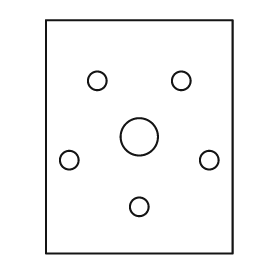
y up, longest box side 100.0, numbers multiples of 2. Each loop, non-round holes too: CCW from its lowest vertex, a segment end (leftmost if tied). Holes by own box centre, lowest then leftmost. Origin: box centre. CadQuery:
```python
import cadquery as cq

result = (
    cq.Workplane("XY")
    .moveTo(-40.0, -50.0)
    .lineTo(40.0, -50.0)
    .lineTo(40.0, 50.0)
    .lineTo(-40.0, 50.0)
    .close()
    .moveTo(0.0, -30.0)
    .circle(4.0)
    .moveTo(-30.0, -10.0)
    .circle(4.0)
    .moveTo(30.0, -10.0)
    .circle(4.0)
    .moveTo(0.0, 0.0)
    .circle(8.0)
    .moveTo(-18.0, 24.0)
    .circle(4.0)
    .moveTo(18.0, 24.0)
    .circle(4.0)
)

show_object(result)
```